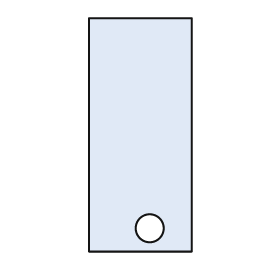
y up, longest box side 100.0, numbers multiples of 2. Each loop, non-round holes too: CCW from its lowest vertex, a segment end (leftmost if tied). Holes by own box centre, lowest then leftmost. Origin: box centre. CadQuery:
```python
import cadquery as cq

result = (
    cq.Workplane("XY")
    .moveTo(-22.0, -50.0)
    .lineTo(22.0, -50.0)
    .lineTo(22.0, 50.0)
    .lineTo(-22.0, 50.0)
    .close()
    .moveTo(4.0, -40.0)
    .circle(6.0)
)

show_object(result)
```